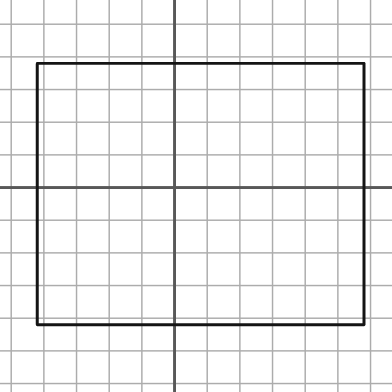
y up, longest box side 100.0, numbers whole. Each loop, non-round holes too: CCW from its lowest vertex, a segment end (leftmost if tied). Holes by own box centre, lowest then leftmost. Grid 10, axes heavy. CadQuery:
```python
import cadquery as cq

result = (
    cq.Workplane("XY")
    .moveTo(-42.0, -42.0)
    .lineTo(58.0, -42.0)
    .lineTo(58.0, 38.0)
    .lineTo(-42.0, 38.0)
    .close()
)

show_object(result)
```